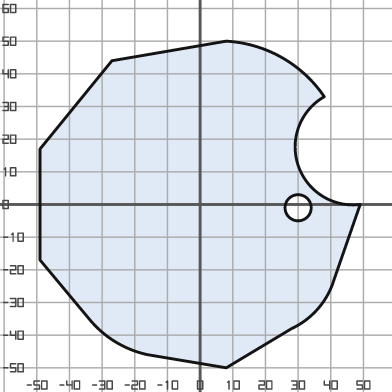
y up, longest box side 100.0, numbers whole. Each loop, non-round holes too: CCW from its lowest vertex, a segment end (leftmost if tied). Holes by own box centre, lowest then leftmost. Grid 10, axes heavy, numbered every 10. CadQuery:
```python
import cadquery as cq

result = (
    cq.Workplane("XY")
    .moveTo(8.0, -50.0)
    .lineTo(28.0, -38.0)
    .threePointArc((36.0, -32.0), (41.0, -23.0))
    .lineTo(49.0, 0.0)
    .threePointArc((30.0, 12.0), (38.0, 33.0))
    .threePointArc((25.0, 45.0), (8.0, 50.0))
    .lineTo(-27.0, 44.0)
    .lineTo(-49.0, 17.0)
    .lineTo(-49.0, -17.0)
    .lineTo(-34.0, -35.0)
    .threePointArc((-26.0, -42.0), (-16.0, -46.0))
    .close()
    .moveTo(30.0, -1.0)
    .circle(4.0)
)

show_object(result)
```